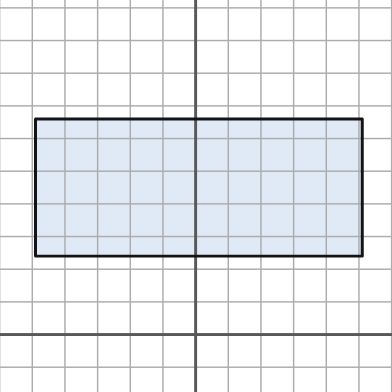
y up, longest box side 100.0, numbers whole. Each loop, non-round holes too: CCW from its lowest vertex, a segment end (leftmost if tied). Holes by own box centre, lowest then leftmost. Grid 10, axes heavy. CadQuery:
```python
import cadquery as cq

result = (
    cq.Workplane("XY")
    .moveTo(-49.0, 24.0)
    .lineTo(51.0, 24.0)
    .lineTo(51.0, 66.0)
    .lineTo(-49.0, 66.0)
    .close()
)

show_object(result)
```